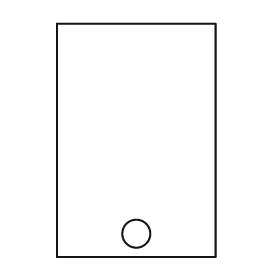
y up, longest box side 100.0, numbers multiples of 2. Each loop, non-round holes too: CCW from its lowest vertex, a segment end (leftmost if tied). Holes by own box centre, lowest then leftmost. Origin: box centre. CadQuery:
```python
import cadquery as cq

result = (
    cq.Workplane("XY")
    .moveTo(-34.0, -50.0)
    .lineTo(34.0, -50.0)
    .lineTo(34.0, 50.0)
    .lineTo(-34.0, 50.0)
    .close()
    .moveTo(0.0, -40.0)
    .circle(6.0)
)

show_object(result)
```